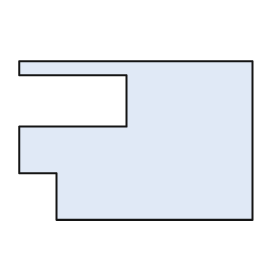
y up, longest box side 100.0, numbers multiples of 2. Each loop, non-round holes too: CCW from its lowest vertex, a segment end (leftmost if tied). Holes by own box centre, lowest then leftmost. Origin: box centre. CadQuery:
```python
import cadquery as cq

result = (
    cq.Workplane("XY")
    .moveTo(-34.0, -34.0)
    .lineTo(50.0, -34.0)
    .lineTo(50.0, 34.0)
    .lineTo(-50.0, 34.0)
    .lineTo(-50.0, 28.0)
    .lineTo(-4.0, 28.0)
    .lineTo(-4.0, 6.0)
    .lineTo(-50.0, 6.0)
    .lineTo(-50.0, -14.0)
    .lineTo(-34.0, -14.0)
    .close()
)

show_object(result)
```